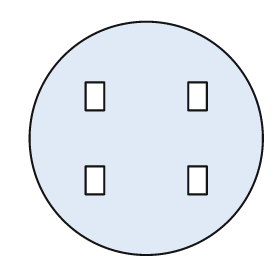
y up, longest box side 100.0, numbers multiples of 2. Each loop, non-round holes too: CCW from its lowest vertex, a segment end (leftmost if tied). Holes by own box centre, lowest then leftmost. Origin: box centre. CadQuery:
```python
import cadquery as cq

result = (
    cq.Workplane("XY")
    .moveTo(0.0, 0.0)
    .circle(50.0)
    .moveTo(-26.0, -24.0)
    .lineTo(-18.0, -24.0)
    .lineTo(-18.0, -12.0)
    .lineTo(-26.0, -12.0)
    .close()
    .moveTo(18.0, -24.0)
    .lineTo(26.0, -24.0)
    .lineTo(26.0, -12.0)
    .lineTo(18.0, -12.0)
    .close()
    .moveTo(-26.0, 12.0)
    .lineTo(-18.0, 12.0)
    .lineTo(-18.0, 24.0)
    .lineTo(-26.0, 24.0)
    .close()
    .moveTo(18.0, 12.0)
    .lineTo(26.0, 12.0)
    .lineTo(26.0, 24.0)
    .lineTo(18.0, 24.0)
    .close()
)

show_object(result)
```